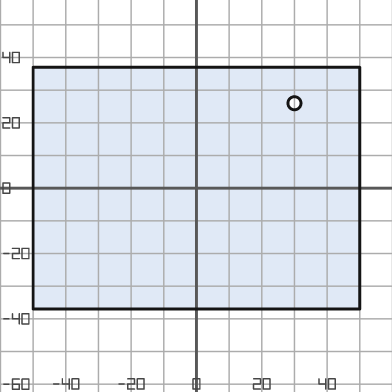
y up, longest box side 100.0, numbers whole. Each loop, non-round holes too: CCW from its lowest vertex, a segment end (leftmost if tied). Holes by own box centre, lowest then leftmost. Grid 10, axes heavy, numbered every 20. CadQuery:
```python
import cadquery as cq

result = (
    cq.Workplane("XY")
    .moveTo(-50.0, -37.0)
    .lineTo(50.0, -37.0)
    .lineTo(50.0, 37.0)
    .lineTo(-50.0, 37.0)
    .close()
    .moveTo(30.0, 26.0)
    .circle(2.0)
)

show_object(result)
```